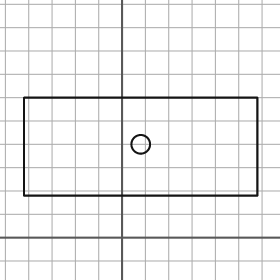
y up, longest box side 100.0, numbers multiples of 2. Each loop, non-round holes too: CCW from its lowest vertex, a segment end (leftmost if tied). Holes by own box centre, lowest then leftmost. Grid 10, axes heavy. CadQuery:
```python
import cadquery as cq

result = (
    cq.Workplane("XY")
    .moveTo(-42.0, 18.0)
    .lineTo(58.0, 18.0)
    .lineTo(58.0, 60.0)
    .lineTo(-42.0, 60.0)
    .close()
    .moveTo(8.0, 40.0)
    .circle(4.0)
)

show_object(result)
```